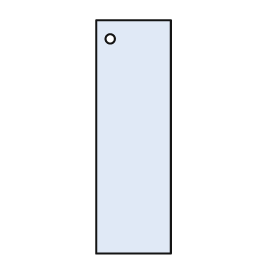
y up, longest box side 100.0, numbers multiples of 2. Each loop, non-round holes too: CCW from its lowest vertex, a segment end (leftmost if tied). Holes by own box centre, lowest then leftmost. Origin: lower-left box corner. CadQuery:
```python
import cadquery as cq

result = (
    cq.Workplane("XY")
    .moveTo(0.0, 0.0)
    .lineTo(32.0, 0.0)
    .lineTo(32.0, 100.0)
    .lineTo(0.0, 100.0)
    .close()
    .moveTo(6.0, 92.0)
    .circle(2.0)
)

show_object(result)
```